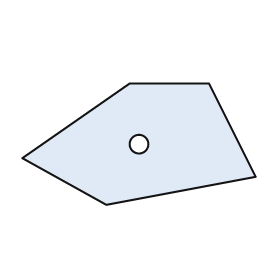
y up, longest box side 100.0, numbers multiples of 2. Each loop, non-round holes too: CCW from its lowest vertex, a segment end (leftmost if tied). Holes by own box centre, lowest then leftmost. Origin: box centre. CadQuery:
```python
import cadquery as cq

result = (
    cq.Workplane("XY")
    .moveTo(-14.0, -26.0)
    .lineTo(50.0, -14.0)
    .lineTo(30.0, 26.0)
    .lineTo(-4.0, 26.0)
    .lineTo(-50.0, -6.0)
    .close()
    .moveTo(0.0, 0.0)
    .circle(4.0)
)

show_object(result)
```